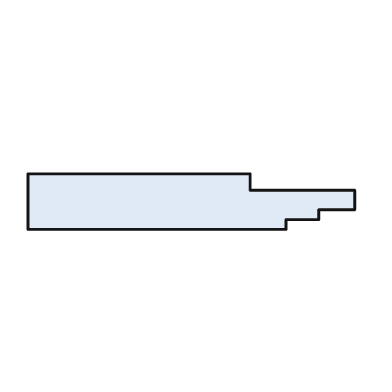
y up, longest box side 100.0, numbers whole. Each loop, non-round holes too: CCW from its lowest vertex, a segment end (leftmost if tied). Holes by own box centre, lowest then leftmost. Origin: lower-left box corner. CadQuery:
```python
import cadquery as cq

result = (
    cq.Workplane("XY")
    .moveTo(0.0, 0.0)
    .lineTo(79.0, 0.0)
    .lineTo(79.0, 3.0)
    .lineTo(89.0, 3.0)
    .lineTo(89.0, 6.0)
    .lineTo(100.0, 6.0)
    .lineTo(100.0, 12.0)
    .lineTo(68.0, 12.0)
    .lineTo(68.0, 17.0)
    .lineTo(0.0, 17.0)
    .close()
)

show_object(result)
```